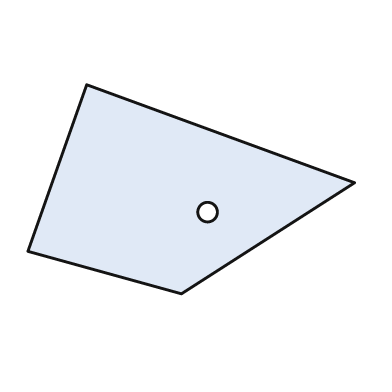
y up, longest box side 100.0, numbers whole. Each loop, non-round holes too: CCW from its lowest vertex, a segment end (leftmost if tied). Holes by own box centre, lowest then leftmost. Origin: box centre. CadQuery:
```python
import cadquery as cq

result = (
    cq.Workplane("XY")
    .moveTo(-3.0, -32.0)
    .lineTo(50.0, 2.0)
    .lineTo(-32.0, 32.0)
    .lineTo(-50.0, -19.0)
    .close()
    .moveTo(5.0, -7.0)
    .circle(3.0)
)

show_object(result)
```